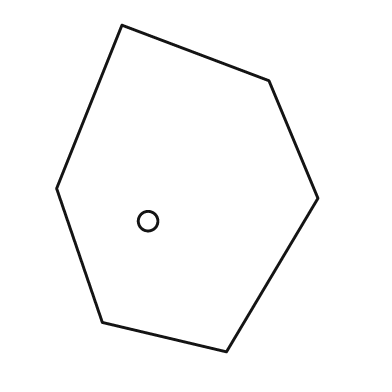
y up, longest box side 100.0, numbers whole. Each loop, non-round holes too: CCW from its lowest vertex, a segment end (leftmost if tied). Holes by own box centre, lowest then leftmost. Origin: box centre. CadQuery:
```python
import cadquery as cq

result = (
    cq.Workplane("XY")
    .moveTo(12.0, -50.0)
    .lineTo(40.0, -3.0)
    .lineTo(25.0, 33.0)
    .lineTo(-20.0, 50.0)
    .lineTo(-40.0, 0.0)
    .lineTo(-26.0, -41.0)
    .close()
    .moveTo(-12.0, -10.0)
    .circle(3.0)
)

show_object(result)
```